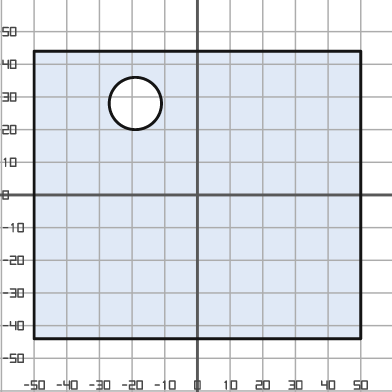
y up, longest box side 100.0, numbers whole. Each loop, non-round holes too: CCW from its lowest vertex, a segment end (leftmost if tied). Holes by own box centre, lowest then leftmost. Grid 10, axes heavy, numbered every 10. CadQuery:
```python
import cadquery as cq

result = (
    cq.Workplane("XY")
    .moveTo(-50.0, -44.0)
    .lineTo(50.0, -44.0)
    .lineTo(50.0, 44.0)
    .lineTo(-50.0, 44.0)
    .close()
    .moveTo(-19.0, 28.0)
    .circle(8.0)
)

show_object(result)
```